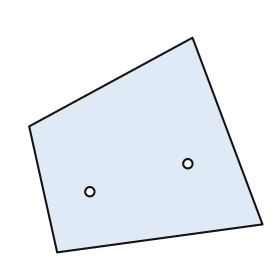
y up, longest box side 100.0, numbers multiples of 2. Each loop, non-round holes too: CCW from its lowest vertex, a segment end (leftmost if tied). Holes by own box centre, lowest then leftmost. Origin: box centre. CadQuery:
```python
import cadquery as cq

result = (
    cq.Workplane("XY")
    .moveTo(-38.0, -46.0)
    .lineTo(50.0, -34.0)
    .lineTo(20.0, 46.0)
    .lineTo(-50.0, 8.0)
    .close()
    .moveTo(-24.0, -20.0)
    .circle(2.0)
    .moveTo(18.0, -8.0)
    .circle(2.0)
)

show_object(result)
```